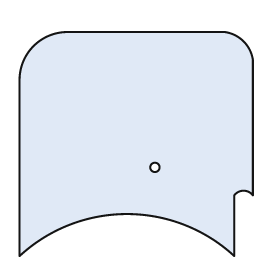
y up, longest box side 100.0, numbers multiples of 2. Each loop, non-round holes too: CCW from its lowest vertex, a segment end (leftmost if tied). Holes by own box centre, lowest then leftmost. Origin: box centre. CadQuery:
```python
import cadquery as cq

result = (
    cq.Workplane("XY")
    .moveTo(-50.0, -48.0)
    .threePointArc((-4.0, -30.0), (42.0, -48.0))
    .lineTo(42.0, -22.0)
    .threePointArc((46.0, -20.0), (50.0, -22.0))
    .lineTo(50.0, 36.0)
    .threePointArc((46.0, 44.0), (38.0, 48.0))
    .lineTo(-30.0, 48.0)
    .threePointArc((-44.0, 42.0), (-50.0, 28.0))
    .close()
    .moveTo(8.0, -10.0)
    .circle(2.0)
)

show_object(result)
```